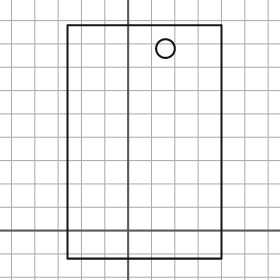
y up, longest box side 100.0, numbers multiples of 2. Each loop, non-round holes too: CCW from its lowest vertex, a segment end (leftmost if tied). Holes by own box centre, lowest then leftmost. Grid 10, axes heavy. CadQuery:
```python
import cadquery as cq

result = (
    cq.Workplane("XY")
    .moveTo(-26.0, -12.0)
    .lineTo(40.0, -12.0)
    .lineTo(40.0, 88.0)
    .lineTo(-26.0, 88.0)
    .close()
    .moveTo(16.0, 78.0)
    .circle(4.0)
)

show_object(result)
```